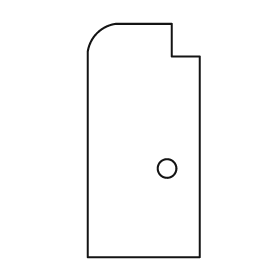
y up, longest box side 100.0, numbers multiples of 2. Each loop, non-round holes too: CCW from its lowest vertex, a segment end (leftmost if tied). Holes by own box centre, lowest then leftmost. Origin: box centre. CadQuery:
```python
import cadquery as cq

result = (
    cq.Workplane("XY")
    .moveTo(-24.0, -50.0)
    .lineTo(24.0, -50.0)
    .lineTo(24.0, 36.0)
    .lineTo(12.0, 36.0)
    .lineTo(12.0, 50.0)
    .lineTo(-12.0, 50.0)
    .threePointArc((-20.0, 46.0), (-24.0, 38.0))
    .close()
    .moveTo(10.0, -12.0)
    .circle(4.0)
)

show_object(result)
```